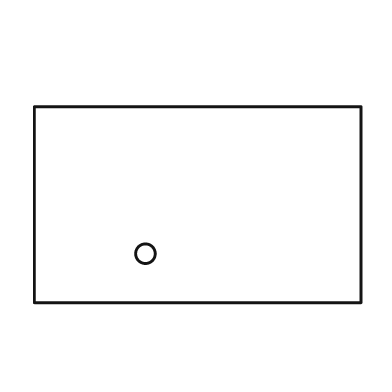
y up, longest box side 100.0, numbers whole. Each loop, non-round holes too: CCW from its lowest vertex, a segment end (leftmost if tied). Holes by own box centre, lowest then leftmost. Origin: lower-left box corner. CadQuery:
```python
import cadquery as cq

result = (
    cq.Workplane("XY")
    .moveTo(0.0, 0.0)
    .lineTo(100.0, 0.0)
    .lineTo(100.0, 60.0)
    .lineTo(0.0, 60.0)
    .close()
    .moveTo(34.0, 15.0)
    .circle(3.0)
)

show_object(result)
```